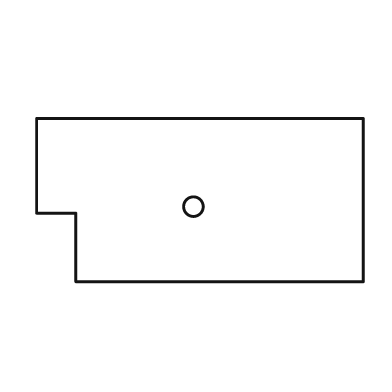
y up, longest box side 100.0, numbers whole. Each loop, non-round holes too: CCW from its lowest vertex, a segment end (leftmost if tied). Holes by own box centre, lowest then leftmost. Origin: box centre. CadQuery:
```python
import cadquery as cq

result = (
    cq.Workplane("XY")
    .moveTo(-38.0, -25.0)
    .lineTo(50.0, -25.0)
    .lineTo(50.0, 25.0)
    .lineTo(-50.0, 25.0)
    .lineTo(-50.0, -4.0)
    .lineTo(-38.0, -4.0)
    .close()
    .moveTo(-2.0, -2.0)
    .circle(3.0)
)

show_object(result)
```